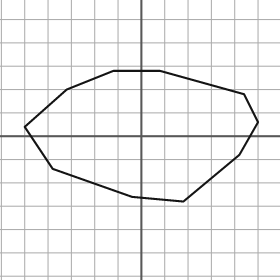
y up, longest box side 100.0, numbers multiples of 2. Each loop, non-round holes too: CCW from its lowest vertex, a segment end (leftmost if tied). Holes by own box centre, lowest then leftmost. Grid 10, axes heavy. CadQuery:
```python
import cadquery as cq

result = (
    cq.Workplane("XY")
    .moveTo(18.0, -28.0)
    .lineTo(42.0, -8.0)
    .lineTo(50.0, 6.0)
    .lineTo(44.0, 18.0)
    .lineTo(8.0, 28.0)
    .lineTo(-12.0, 28.0)
    .lineTo(-32.0, 20.0)
    .lineTo(-50.0, 4.0)
    .lineTo(-38.0, -14.0)
    .lineTo(-4.0, -26.0)
    .close()
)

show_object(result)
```